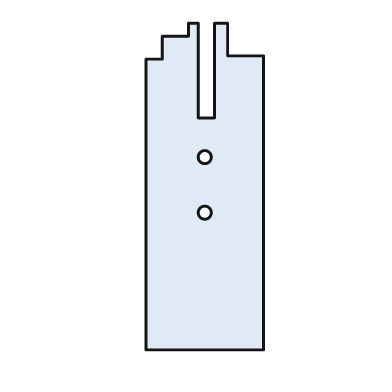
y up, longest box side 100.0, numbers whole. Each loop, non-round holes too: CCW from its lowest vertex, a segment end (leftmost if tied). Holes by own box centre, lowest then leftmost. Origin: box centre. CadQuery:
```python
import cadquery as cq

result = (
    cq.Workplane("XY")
    .moveTo(-18.0, -50.0)
    .lineTo(18.0, -50.0)
    .lineTo(18.0, 40.0)
    .lineTo(7.0, 40.0)
    .lineTo(7.0, 50.0)
    .lineTo(3.0, 50.0)
    .lineTo(3.0, 21.0)
    .lineTo(-2.0, 21.0)
    .lineTo(-2.0, 50.0)
    .lineTo(-5.0, 50.0)
    .lineTo(-5.0, 46.0)
    .lineTo(-13.0, 46.0)
    .lineTo(-13.0, 39.0)
    .lineTo(-18.0, 39.0)
    .close()
    .moveTo(0.0, -8.0)
    .circle(2.0)
    .moveTo(0.0, 9.0)
    .circle(2.0)
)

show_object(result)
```